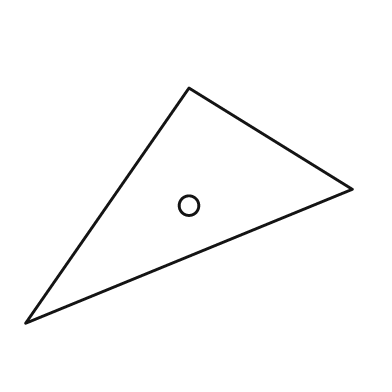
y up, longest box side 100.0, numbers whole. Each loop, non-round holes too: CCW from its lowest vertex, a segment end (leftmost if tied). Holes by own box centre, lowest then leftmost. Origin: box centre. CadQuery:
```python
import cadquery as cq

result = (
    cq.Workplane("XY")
    .moveTo(-50.0, -36.0)
    .lineTo(50.0, 5.0)
    .lineTo(0.0, 36.0)
    .close()
    .moveTo(0.0, 0.0)
    .circle(3.0)
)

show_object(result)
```